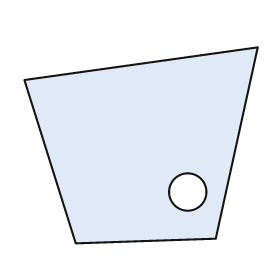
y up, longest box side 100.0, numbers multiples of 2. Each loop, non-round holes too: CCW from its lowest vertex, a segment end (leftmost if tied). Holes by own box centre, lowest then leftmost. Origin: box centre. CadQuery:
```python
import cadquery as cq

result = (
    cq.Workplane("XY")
    .moveTo(-28.0, -42.0)
    .lineTo(32.0, -40.0)
    .lineTo(50.0, 42.0)
    .lineTo(-50.0, 28.0)
    .close()
    .moveTo(20.0, -20.0)
    .circle(8.0)
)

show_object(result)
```